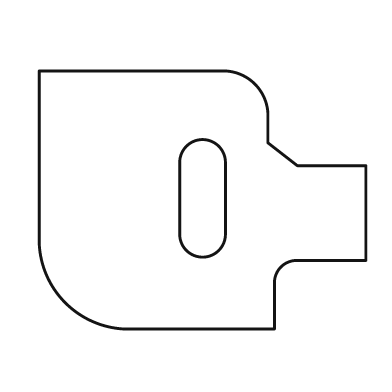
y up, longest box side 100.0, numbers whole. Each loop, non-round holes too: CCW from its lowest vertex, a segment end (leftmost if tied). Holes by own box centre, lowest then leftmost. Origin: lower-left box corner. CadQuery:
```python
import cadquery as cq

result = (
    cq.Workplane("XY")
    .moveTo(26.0, 0.0)
    .lineTo(72.0, 0.0)
    .lineTo(72.0, 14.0)
    .threePointArc((74.0, 19.0), (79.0, 21.0))
    .lineTo(100.0, 21.0)
    .lineTo(100.0, 50.0)
    .lineTo(79.0, 50.0)
    .lineTo(70.0, 57.0)
    .lineTo(70.0, 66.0)
    .threePointArc((66.0, 75.0), (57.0, 79.0))
    .lineTo(0.0, 79.0)
    .lineTo(0.0, 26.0)
    .threePointArc((8.0, 8.0), (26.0, 0.0))
    .close()
    .moveTo(43.0, 29.0)
    .threePointArc((50.0, 22.0), (57.0, 29.0))
    .lineTo(57.0, 51.0)
    .threePointArc((50.0, 58.0), (43.0, 51.0))
    .close()
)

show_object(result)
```